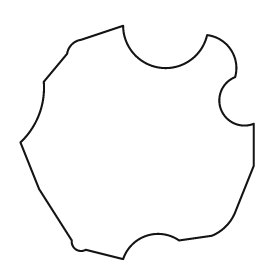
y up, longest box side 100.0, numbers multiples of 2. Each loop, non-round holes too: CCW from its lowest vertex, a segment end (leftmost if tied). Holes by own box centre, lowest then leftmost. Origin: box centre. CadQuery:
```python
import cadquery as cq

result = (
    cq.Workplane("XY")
    .moveTo(-6.0, -50.0)
    .threePointArc((4.0, -40.0), (18.0, -42.0))
    .lineTo(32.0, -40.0)
    .threePointArc((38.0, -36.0), (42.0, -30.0))
    .lineTo(50.0, -10.0)
    .lineTo(50.0, 8.0)
    .threePointArc((36.0, 14.0), (42.0, 28.0))
    .threePointArc((40.0, 40.0), (30.0, 46.0))
    .threePointArc((10.0, 32.0), (-6.0, 50.0))
    .lineTo(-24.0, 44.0)
    .threePointArc((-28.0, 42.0), (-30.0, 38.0))
    .lineTo(-40.0, 26.0)
    .threePointArc((-42.0, 12.0), (-50.0, 0.0))
    .lineTo(-42.0, -20.0)
    .lineTo(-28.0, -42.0)
    .threePointArc((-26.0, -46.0), (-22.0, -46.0))
    .close()
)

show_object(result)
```